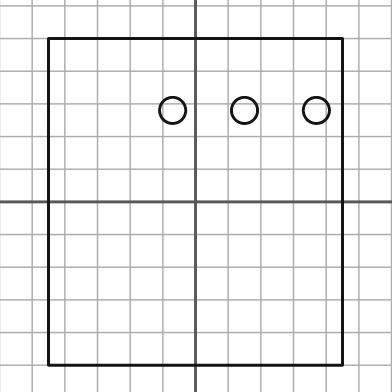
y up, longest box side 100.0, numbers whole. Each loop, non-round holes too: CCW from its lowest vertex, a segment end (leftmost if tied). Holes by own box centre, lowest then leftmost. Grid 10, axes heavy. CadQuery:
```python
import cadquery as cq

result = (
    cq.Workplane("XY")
    .moveTo(-45.0, -50.0)
    .lineTo(45.0, -50.0)
    .lineTo(45.0, 50.0)
    .lineTo(-45.0, 50.0)
    .close()
    .moveTo(-7.0, 28.0)
    .circle(4.0)
    .moveTo(15.0, 28.0)
    .circle(4.0)
    .moveTo(37.0, 28.0)
    .circle(4.0)
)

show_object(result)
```